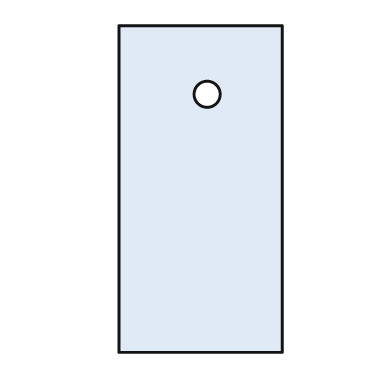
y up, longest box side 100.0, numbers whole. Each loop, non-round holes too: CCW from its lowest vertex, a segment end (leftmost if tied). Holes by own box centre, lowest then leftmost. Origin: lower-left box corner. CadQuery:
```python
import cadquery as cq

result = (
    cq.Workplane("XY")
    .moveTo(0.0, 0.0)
    .lineTo(50.0, 0.0)
    .lineTo(50.0, 100.0)
    .lineTo(0.0, 100.0)
    .close()
    .moveTo(27.0, 79.0)
    .circle(4.0)
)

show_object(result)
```